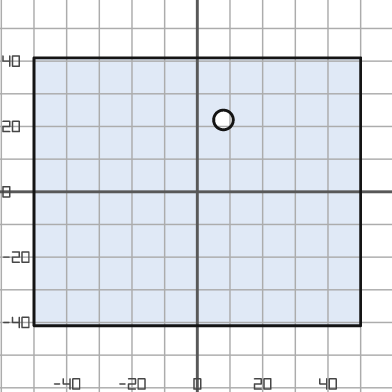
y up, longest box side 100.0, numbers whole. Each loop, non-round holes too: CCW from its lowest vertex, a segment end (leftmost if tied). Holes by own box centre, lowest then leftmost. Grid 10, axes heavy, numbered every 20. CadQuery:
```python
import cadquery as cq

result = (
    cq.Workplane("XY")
    .moveTo(-50.0, -41.0)
    .lineTo(50.0, -41.0)
    .lineTo(50.0, 41.0)
    .lineTo(-50.0, 41.0)
    .close()
    .moveTo(8.0, 22.0)
    .circle(3.0)
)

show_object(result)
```